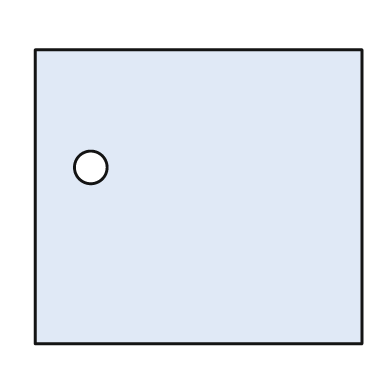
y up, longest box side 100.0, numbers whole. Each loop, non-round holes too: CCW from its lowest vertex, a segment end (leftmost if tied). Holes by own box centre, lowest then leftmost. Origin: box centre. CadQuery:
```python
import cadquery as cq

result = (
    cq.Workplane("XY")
    .moveTo(-50.0, -45.0)
    .lineTo(50.0, -45.0)
    .lineTo(50.0, 45.0)
    .lineTo(-50.0, 45.0)
    .close()
    .moveTo(-33.0, 9.0)
    .circle(5.0)
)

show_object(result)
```